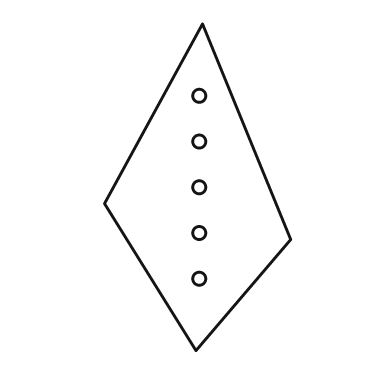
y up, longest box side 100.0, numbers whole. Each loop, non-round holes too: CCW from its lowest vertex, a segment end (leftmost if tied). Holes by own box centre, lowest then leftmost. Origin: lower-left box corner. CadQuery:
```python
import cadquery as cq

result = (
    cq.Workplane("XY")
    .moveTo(28.0, 0.0)
    .lineTo(57.0, 34.0)
    .lineTo(30.0, 100.0)
    .lineTo(0.0, 45.0)
    .close()
    .moveTo(29.0, 22.0)
    .circle(2.0)
    .moveTo(29.0, 36.0)
    .circle(2.0)
    .moveTo(29.0, 50.0)
    .circle(2.0)
    .moveTo(29.0, 64.0)
    .circle(2.0)
    .moveTo(29.0, 78.0)
    .circle(2.0)
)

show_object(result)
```